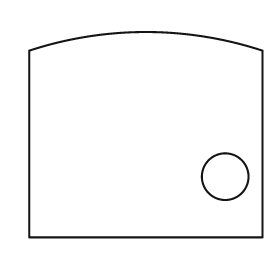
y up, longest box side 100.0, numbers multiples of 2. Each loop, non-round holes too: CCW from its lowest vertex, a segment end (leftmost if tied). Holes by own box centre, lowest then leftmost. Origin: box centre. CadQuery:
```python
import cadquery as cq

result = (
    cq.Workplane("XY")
    .moveTo(-50.0, -44.0)
    .lineTo(50.0, -44.0)
    .lineTo(50.0, 36.0)
    .threePointArc((0.0, 44.0), (-50.0, 36.0))
    .close()
    .moveTo(34.0, -18.0)
    .circle(10.0)
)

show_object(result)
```